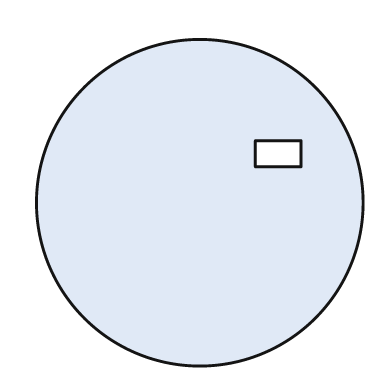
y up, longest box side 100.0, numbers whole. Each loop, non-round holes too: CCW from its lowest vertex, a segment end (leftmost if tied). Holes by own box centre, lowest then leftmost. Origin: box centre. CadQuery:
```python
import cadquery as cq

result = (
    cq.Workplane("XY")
    .moveTo(0.0, 0.0)
    .circle(50.0)
    .moveTo(17.0, 11.0)
    .lineTo(31.0, 11.0)
    .lineTo(31.0, 19.0)
    .lineTo(17.0, 19.0)
    .close()
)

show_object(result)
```